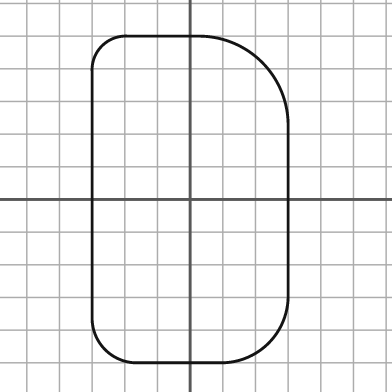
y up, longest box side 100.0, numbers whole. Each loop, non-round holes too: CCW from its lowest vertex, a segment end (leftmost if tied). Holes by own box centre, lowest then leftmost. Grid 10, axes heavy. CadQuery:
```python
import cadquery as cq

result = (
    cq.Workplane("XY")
    .moveTo(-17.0, -50.0)
    .lineTo(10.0, -50.0)
    .threePointArc((24.0, -44.0), (30.0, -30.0))
    .lineTo(30.0, 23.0)
    .threePointArc((22.0, 42.0), (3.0, 50.0))
    .lineTo(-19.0, 50.0)
    .threePointArc((-27.0, 47.0), (-30.0, 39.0))
    .lineTo(-30.0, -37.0)
    .threePointArc((-26.0, -46.0), (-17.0, -50.0))
    .close()
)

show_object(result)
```